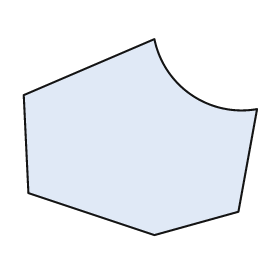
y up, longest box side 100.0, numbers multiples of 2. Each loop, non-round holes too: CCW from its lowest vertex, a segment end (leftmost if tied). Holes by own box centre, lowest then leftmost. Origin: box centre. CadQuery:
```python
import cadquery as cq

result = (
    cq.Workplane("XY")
    .moveTo(6.0, -42.0)
    .lineTo(42.0, -32.0)
    .lineTo(50.0, 12.0)
    .threePointArc((22.0, 18.0), (6.0, 42.0))
    .lineTo(-50.0, 18.0)
    .lineTo(-48.0, -24.0)
    .close()
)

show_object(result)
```